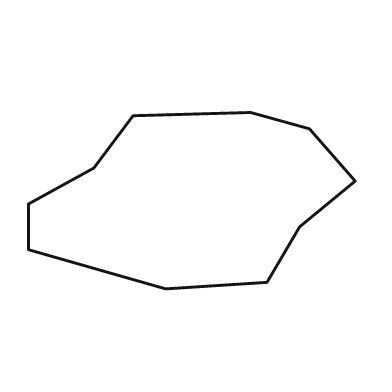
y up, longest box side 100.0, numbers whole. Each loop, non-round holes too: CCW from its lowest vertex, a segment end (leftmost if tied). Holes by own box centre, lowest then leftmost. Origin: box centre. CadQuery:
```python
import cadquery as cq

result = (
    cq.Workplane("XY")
    .moveTo(-8.0, -27.0)
    .lineTo(23.0, -25.0)
    .lineTo(33.0, -8.0)
    .lineTo(50.0, 6.0)
    .lineTo(36.0, 22.0)
    .lineTo(18.0, 27.0)
    .lineTo(-18.0, 26.0)
    .lineTo(-30.0, 10.0)
    .lineTo(-50.0, -1.0)
    .lineTo(-50.0, -15.0)
    .close()
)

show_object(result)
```